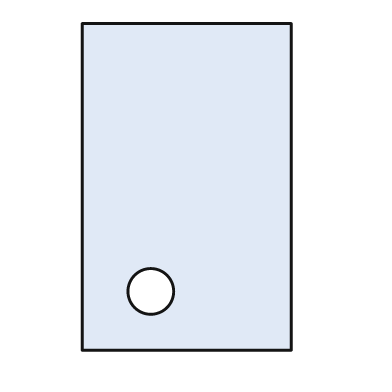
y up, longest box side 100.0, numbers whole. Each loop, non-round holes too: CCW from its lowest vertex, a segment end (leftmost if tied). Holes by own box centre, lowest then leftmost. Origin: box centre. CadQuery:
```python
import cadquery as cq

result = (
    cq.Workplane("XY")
    .moveTo(-32.0, -50.0)
    .lineTo(32.0, -50.0)
    .lineTo(32.0, 50.0)
    .lineTo(-32.0, 50.0)
    .close()
    .moveTo(-11.0, -32.0)
    .circle(7.0)
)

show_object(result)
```